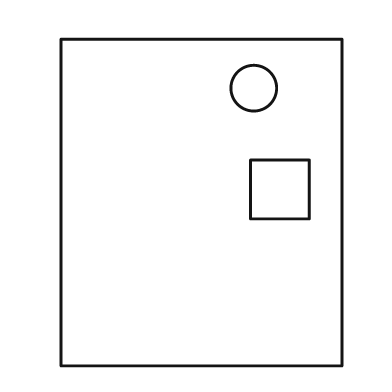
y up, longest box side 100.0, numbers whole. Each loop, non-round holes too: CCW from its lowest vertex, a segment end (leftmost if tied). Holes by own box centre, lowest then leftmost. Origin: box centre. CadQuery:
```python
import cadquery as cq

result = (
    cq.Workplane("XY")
    .moveTo(-43.0, -50.0)
    .lineTo(43.0, -50.0)
    .lineTo(43.0, 50.0)
    .lineTo(-43.0, 50.0)
    .close()
    .moveTo(15.0, -5.0)
    .lineTo(33.0, -5.0)
    .lineTo(33.0, 13.0)
    .lineTo(15.0, 13.0)
    .close()
    .moveTo(16.0, 35.0)
    .circle(7.0)
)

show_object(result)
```